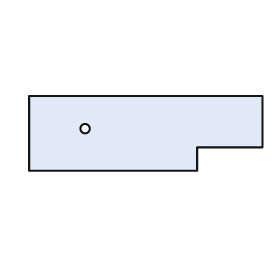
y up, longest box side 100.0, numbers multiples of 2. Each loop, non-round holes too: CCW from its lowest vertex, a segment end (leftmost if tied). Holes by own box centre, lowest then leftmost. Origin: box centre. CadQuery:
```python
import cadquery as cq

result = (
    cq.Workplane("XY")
    .moveTo(-50.0, -16.0)
    .lineTo(22.0, -16.0)
    .lineTo(22.0, -6.0)
    .lineTo(50.0, -6.0)
    .lineTo(50.0, 16.0)
    .lineTo(-50.0, 16.0)
    .close()
    .moveTo(-26.0, 2.0)
    .circle(2.0)
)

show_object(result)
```